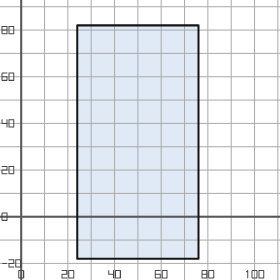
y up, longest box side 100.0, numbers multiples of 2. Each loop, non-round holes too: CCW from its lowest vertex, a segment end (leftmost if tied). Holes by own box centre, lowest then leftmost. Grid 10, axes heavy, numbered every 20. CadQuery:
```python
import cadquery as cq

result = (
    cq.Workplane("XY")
    .moveTo(24.0, -18.0)
    .lineTo(76.0, -18.0)
    .lineTo(76.0, 82.0)
    .lineTo(24.0, 82.0)
    .close()
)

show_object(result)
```